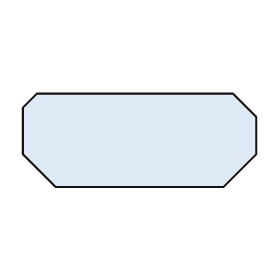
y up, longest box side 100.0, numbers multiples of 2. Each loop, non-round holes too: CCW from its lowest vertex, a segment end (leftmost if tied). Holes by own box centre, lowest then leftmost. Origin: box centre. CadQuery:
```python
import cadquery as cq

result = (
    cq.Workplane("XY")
    .moveTo(-36.0, -20.0)
    .lineTo(36.0, -20.0)
    .lineTo(50.0, -6.0)
    .lineTo(50.0, 10.0)
    .lineTo(40.0, 20.0)
    .lineTo(-44.0, 20.0)
    .lineTo(-50.0, 14.0)
    .lineTo(-50.0, -6.0)
    .close()
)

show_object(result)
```